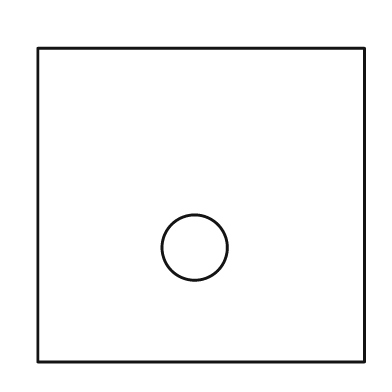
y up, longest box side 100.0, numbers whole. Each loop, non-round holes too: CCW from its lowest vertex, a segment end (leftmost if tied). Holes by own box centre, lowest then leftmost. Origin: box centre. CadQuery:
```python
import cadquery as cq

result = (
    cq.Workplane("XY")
    .moveTo(-50.0, -48.0)
    .lineTo(50.0, -48.0)
    .lineTo(50.0, 48.0)
    .lineTo(-50.0, 48.0)
    .close()
    .moveTo(-2.0, -13.0)
    .circle(10.0)
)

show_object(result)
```